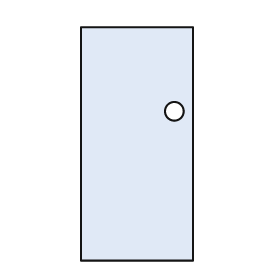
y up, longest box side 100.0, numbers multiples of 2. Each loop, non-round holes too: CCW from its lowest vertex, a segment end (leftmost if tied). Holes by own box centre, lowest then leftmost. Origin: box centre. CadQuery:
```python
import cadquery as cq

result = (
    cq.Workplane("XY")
    .moveTo(-24.0, -50.0)
    .lineTo(24.0, -50.0)
    .lineTo(24.0, 50.0)
    .lineTo(-24.0, 50.0)
    .close()
    .moveTo(16.0, 14.0)
    .circle(4.0)
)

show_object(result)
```